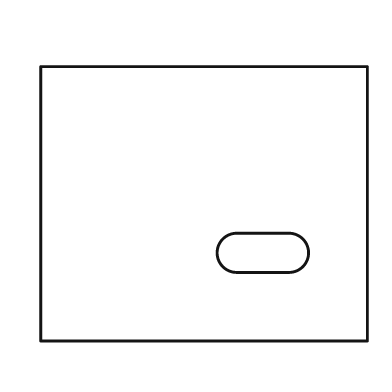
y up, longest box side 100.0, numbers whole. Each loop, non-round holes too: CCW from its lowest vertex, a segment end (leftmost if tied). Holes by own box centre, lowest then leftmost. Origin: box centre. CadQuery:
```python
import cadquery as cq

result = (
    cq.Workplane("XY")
    .moveTo(-50.0, -42.0)
    .lineTo(50.0, -42.0)
    .lineTo(50.0, 42.0)
    .lineTo(-50.0, 42.0)
    .close()
    .moveTo(10.0, -21.0)
    .lineTo(26.0, -21.0)
    .threePointArc((32.0, -15.0), (26.0, -9.0))
    .lineTo(10.0, -9.0)
    .threePointArc((4.0, -15.0), (10.0, -21.0))
    .close()
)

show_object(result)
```